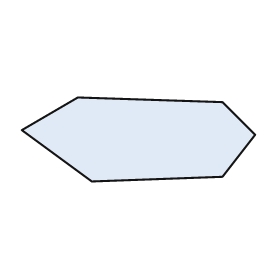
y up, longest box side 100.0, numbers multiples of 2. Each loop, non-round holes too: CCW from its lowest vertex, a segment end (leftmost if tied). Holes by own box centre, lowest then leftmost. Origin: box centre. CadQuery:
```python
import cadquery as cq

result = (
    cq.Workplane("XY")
    .moveTo(-20.0, -18.0)
    .lineTo(36.0, -16.0)
    .lineTo(50.0, 2.0)
    .lineTo(36.0, 16.0)
    .lineTo(-26.0, 18.0)
    .lineTo(-50.0, 4.0)
    .close()
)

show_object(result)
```